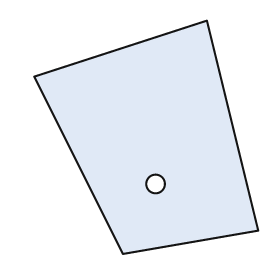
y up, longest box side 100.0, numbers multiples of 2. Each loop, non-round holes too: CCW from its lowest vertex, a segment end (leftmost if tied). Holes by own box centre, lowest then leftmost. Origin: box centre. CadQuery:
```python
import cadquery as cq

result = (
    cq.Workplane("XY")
    .moveTo(-10.0, -50.0)
    .lineTo(48.0, -40.0)
    .lineTo(26.0, 50.0)
    .lineTo(-48.0, 26.0)
    .close()
    .moveTo(4.0, -20.0)
    .circle(4.0)
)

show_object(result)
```